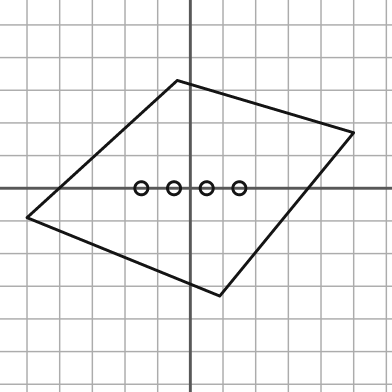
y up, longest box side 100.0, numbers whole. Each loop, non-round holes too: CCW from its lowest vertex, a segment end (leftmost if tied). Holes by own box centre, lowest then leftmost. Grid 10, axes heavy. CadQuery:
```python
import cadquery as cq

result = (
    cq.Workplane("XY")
    .moveTo(9.0, -33.0)
    .lineTo(50.0, 17.0)
    .lineTo(-4.0, 33.0)
    .lineTo(-50.0, -9.0)
    .close()
    .moveTo(-15.0, 0.0)
    .circle(2.0)
    .moveTo(-5.0, 0.0)
    .circle(2.0)
    .moveTo(5.0, 0.0)
    .circle(2.0)
    .moveTo(15.0, 0.0)
    .circle(2.0)
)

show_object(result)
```